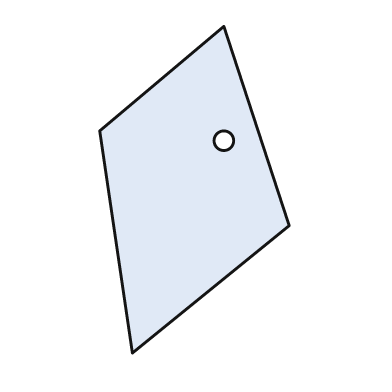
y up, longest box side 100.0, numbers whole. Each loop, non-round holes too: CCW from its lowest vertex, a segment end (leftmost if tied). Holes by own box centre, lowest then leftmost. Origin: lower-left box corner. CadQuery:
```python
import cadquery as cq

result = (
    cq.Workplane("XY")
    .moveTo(10.0, 0.0)
    .lineTo(58.0, 39.0)
    .lineTo(38.0, 100.0)
    .lineTo(0.0, 68.0)
    .close()
    .moveTo(38.0, 65.0)
    .circle(3.0)
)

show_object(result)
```